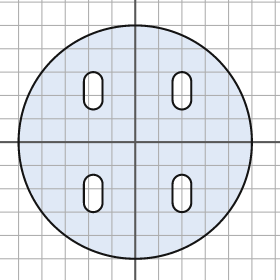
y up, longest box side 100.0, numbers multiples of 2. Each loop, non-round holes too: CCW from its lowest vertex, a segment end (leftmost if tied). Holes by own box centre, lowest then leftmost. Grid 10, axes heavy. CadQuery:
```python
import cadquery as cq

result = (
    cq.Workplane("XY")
    .moveTo(0.0, 0.0)
    .circle(50.0)
    .moveTo(-22.0, -26.0)
    .threePointArc((-18.0, -30.0), (-14.0, -26.0))
    .lineTo(-14.0, -18.0)
    .threePointArc((-18.0, -14.0), (-22.0, -18.0))
    .close()
    .moveTo(16.0, -26.0)
    .threePointArc((20.0, -30.0), (24.0, -26.0))
    .lineTo(24.0, -18.0)
    .threePointArc((20.0, -14.0), (16.0, -18.0))
    .close()
    .moveTo(-22.0, 18.0)
    .threePointArc((-18.0, 14.0), (-14.0, 18.0))
    .lineTo(-14.0, 26.0)
    .threePointArc((-18.0, 30.0), (-22.0, 26.0))
    .close()
    .moveTo(16.0, 18.0)
    .threePointArc((20.0, 14.0), (24.0, 18.0))
    .lineTo(24.0, 26.0)
    .threePointArc((20.0, 30.0), (16.0, 26.0))
    .close()
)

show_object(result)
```